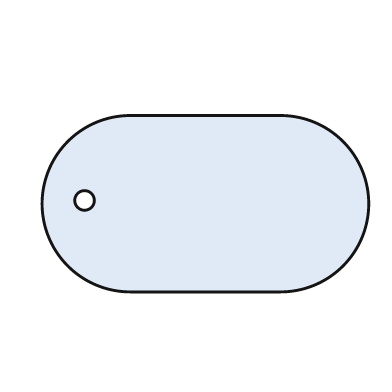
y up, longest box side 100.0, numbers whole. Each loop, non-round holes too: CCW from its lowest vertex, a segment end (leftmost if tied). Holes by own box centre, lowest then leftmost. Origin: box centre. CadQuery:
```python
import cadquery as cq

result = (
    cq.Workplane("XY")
    .moveTo(-23.0, -27.0)
    .lineTo(23.0, -27.0)
    .threePointArc((50.0, 0.0), (23.0, 27.0))
    .lineTo(-23.0, 27.0)
    .threePointArc((-50.0, 0.0), (-23.0, -27.0))
    .close()
    .moveTo(-37.0, 1.0)
    .circle(3.0)
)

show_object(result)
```